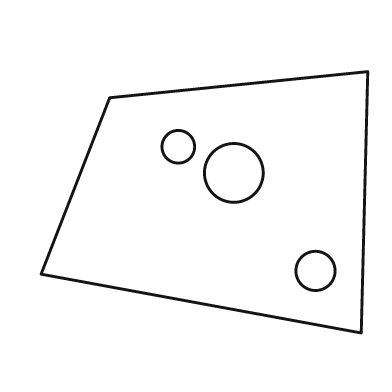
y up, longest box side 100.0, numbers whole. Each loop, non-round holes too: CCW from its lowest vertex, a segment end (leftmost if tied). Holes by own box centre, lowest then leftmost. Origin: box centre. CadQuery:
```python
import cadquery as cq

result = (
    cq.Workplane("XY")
    .moveTo(48.0, -40.0)
    .lineTo(50.0, 40.0)
    .lineTo(-29.0, 32.0)
    .lineTo(-50.0, -22.0)
    .close()
    .moveTo(34.0, -21.0)
    .circle(6.0)
    .moveTo(9.0, 9.0)
    .circle(9.0)
    .moveTo(-8.0, 17.0)
    .circle(5.0)
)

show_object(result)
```